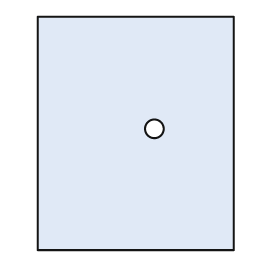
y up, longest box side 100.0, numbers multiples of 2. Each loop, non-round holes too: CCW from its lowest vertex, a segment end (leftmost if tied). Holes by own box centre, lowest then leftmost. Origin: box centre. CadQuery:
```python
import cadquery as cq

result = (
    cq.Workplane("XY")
    .moveTo(-42.0, -50.0)
    .lineTo(42.0, -50.0)
    .lineTo(42.0, 50.0)
    .lineTo(-42.0, 50.0)
    .close()
    .moveTo(8.0, 2.0)
    .circle(4.0)
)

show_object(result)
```